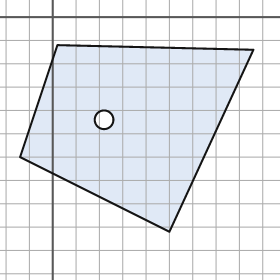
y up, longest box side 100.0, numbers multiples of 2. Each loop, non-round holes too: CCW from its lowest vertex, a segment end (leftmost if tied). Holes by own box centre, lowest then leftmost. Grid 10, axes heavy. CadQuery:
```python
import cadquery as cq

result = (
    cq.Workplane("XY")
    .moveTo(50.0, -92.0)
    .lineTo(86.0, -14.0)
    .lineTo(2.0, -12.0)
    .lineTo(-14.0, -60.0)
    .close()
    .moveTo(22.0, -44.0)
    .circle(4.0)
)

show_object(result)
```